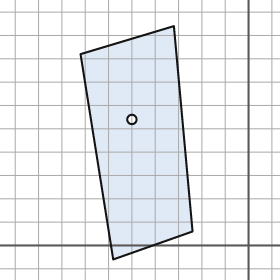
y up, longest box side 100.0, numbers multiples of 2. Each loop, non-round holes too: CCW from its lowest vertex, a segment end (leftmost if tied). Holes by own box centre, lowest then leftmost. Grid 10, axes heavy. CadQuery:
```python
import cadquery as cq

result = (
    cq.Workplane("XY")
    .moveTo(-58.0, -6.0)
    .lineTo(-24.0, 6.0)
    .lineTo(-32.0, 94.0)
    .lineTo(-72.0, 82.0)
    .close()
    .moveTo(-50.0, 54.0)
    .circle(2.0)
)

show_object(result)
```